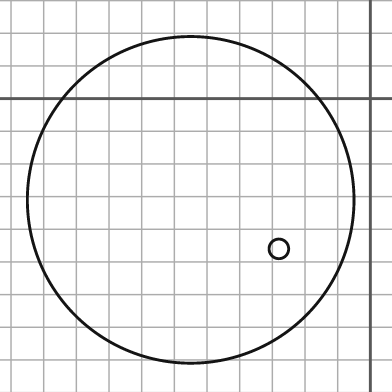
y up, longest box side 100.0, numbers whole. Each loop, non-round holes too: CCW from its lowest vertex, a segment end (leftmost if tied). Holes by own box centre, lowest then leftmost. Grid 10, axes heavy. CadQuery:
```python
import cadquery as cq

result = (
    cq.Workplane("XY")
    .moveTo(-55.0, -31.0)
    .circle(50.0)
    .moveTo(-28.0, -46.0)
    .circle(3.0)
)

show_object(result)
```